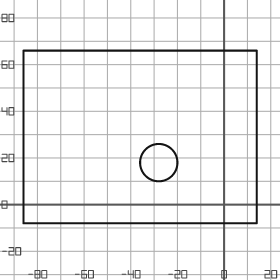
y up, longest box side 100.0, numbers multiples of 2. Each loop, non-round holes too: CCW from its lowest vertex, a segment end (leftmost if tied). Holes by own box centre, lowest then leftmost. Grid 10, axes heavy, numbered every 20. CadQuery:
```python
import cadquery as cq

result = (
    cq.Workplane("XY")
    .moveTo(-86.0, -8.0)
    .lineTo(14.0, -8.0)
    .lineTo(14.0, 66.0)
    .lineTo(-86.0, 66.0)
    .close()
    .moveTo(-28.0, 18.0)
    .circle(8.0)
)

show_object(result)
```